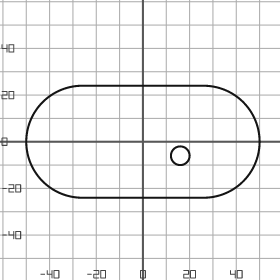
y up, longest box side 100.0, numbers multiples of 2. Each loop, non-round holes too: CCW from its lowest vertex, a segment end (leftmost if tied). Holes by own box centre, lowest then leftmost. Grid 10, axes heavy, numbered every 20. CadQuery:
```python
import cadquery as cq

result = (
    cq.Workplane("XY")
    .moveTo(-26.0, -24.0)
    .lineTo(26.0, -24.0)
    .threePointArc((50.0, 0.0), (26.0, 24.0))
    .lineTo(-26.0, 24.0)
    .threePointArc((-50.0, 0.0), (-26.0, -24.0))
    .close()
    .moveTo(16.0, -6.0)
    .circle(4.0)
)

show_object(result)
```